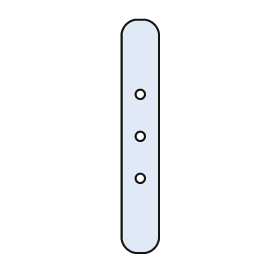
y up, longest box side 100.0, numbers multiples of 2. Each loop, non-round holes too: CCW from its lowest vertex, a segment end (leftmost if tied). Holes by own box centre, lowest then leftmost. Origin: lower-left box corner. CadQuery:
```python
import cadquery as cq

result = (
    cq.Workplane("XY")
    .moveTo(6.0, 0.0)
    .lineTo(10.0, 0.0)
    .threePointArc((14.0, 2.0), (16.0, 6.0))
    .lineTo(16.0, 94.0)
    .threePointArc((14.0, 98.0), (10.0, 100.0))
    .lineTo(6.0, 100.0)
    .threePointArc((2.0, 98.0), (0.0, 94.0))
    .lineTo(0.0, 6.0)
    .threePointArc((2.0, 2.0), (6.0, 0.0))
    .close()
    .moveTo(8.0, 32.0)
    .circle(2.0)
    .moveTo(8.0, 50.0)
    .circle(2.0)
    .moveTo(8.0, 68.0)
    .circle(2.0)
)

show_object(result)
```